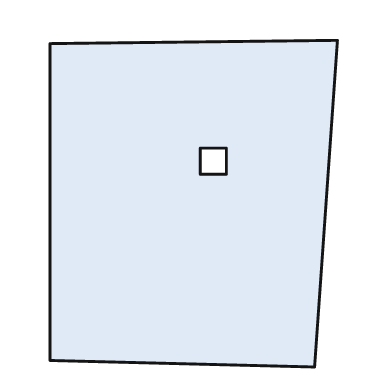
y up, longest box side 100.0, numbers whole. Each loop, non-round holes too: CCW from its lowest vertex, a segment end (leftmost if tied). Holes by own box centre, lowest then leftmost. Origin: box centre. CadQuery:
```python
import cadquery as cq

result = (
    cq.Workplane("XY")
    .moveTo(37.0, -50.0)
    .lineTo(44.0, 50.0)
    .lineTo(-44.0, 49.0)
    .lineTo(-44.0, -48.0)
    .close()
    .moveTo(2.0, 9.0)
    .lineTo(10.0, 9.0)
    .lineTo(10.0, 17.0)
    .lineTo(2.0, 17.0)
    .close()
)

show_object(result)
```